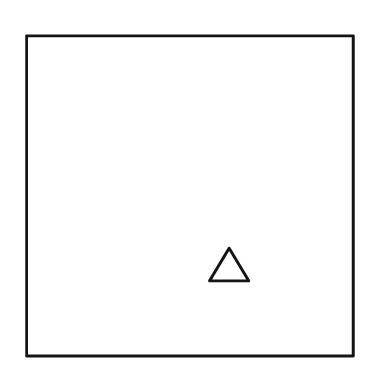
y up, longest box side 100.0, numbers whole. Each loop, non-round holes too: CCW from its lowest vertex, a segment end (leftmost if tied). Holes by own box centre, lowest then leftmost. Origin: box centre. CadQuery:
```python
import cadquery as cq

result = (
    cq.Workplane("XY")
    .moveTo(-50.0, -49.0)
    .lineTo(50.0, -49.0)
    .lineTo(50.0, 49.0)
    .lineTo(-50.0, 49.0)
    .close()
    .moveTo(6.0, -26.0)
    .lineTo(18.0, -26.0)
    .lineTo(12.0, -16.0)
    .close()
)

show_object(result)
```